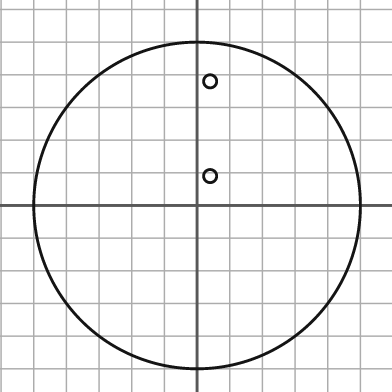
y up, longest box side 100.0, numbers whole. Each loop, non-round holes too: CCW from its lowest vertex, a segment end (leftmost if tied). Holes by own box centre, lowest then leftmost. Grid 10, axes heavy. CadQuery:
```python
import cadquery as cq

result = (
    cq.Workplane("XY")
    .moveTo(0.0, 0.0)
    .circle(50.0)
    .moveTo(4.0, 9.0)
    .circle(2.0)
    .moveTo(4.0, 38.0)
    .circle(2.0)
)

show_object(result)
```